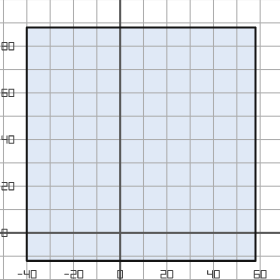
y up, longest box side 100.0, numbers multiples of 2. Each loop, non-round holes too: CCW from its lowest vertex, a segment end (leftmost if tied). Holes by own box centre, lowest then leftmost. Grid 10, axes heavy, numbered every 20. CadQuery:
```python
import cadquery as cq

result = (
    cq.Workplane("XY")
    .moveTo(-40.0, -12.0)
    .lineTo(58.0, -12.0)
    .lineTo(58.0, 88.0)
    .lineTo(-40.0, 88.0)
    .close()
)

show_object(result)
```